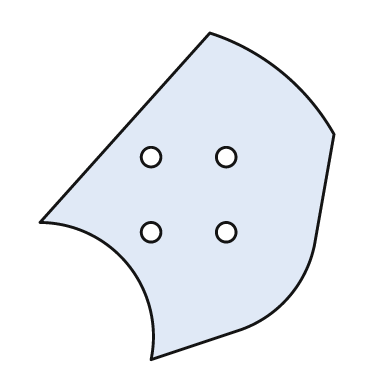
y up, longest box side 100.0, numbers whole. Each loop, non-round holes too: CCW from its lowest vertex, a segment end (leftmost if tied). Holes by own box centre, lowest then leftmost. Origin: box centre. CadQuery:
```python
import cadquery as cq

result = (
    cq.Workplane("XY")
    .moveTo(-11.0, -50.0)
    .lineTo(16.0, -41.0)
    .threePointArc((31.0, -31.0), (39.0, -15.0))
    .lineTo(45.0, 19.0)
    .threePointArc((29.0, 38.0), (7.0, 50.0))
    .lineTo(-45.0, -8.0)
    .threePointArc((-18.0, -21.0), (-11.0, -50.0))
    .close()
    .moveTo(-11.0, -11.0)
    .circle(3.0)
    .moveTo(12.0, -11.0)
    .circle(3.0)
    .moveTo(-11.0, 12.0)
    .circle(3.0)
    .moveTo(12.0, 12.0)
    .circle(3.0)
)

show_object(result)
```